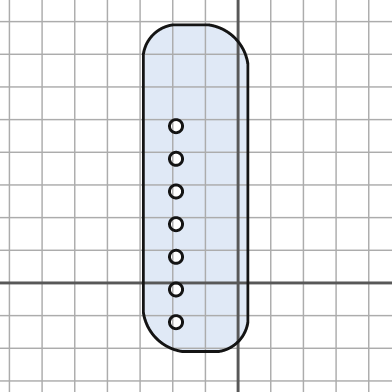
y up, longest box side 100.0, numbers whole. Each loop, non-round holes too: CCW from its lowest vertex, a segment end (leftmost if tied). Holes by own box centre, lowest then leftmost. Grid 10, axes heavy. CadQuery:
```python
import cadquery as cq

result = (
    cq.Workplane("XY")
    .moveTo(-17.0, -21.0)
    .lineTo(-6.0, -21.0)
    .threePointArc((0.0, -18.0), (3.0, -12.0))
    .lineTo(3.0, 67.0)
    .threePointArc((-1.0, 75.0), (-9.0, 79.0))
    .lineTo(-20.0, 79.0)
    .threePointArc((-26.0, 76.0), (-29.0, 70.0))
    .lineTo(-29.0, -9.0)
    .threePointArc((-25.0, -17.0), (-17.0, -21.0))
    .close()
    .moveTo(-19.0, -12.0)
    .circle(2.0)
    .moveTo(-19.0, -2.0)
    .circle(2.0)
    .moveTo(-19.0, 8.0)
    .circle(2.0)
    .moveTo(-19.0, 18.0)
    .circle(2.0)
    .moveTo(-19.0, 28.0)
    .circle(2.0)
    .moveTo(-19.0, 38.0)
    .circle(2.0)
    .moveTo(-19.0, 48.0)
    .circle(2.0)
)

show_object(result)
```